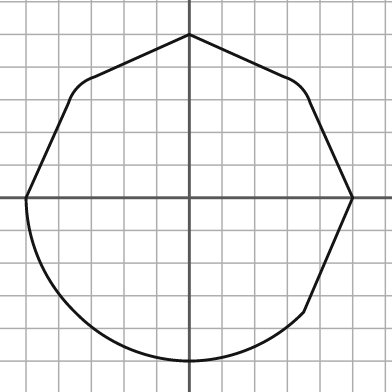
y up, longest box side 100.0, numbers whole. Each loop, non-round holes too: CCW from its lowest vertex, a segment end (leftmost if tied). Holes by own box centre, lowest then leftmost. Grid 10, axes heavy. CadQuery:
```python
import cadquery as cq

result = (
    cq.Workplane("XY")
    .moveTo(0.0, -50.0)
    .threePointArc((19.0, -46.0), (35.0, -35.0))
    .lineTo(50.0, 0.0)
    .lineTo(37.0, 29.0)
    .threePointArc((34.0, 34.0), (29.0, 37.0))
    .lineTo(0.0, 50.0)
    .lineTo(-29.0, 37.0)
    .threePointArc((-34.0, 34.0), (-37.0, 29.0))
    .lineTo(-50.0, 0.0)
    .threePointArc((-46.0, -19.0), (-35.0, -35.0))
    .threePointArc((-19.0, -46.0), (0.0, -50.0))
    .close()
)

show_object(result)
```